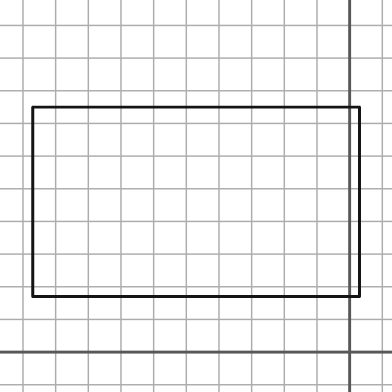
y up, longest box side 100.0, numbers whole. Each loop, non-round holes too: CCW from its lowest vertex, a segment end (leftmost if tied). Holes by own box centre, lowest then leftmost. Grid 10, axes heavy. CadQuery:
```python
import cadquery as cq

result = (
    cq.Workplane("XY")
    .moveTo(-97.0, 17.0)
    .lineTo(3.0, 17.0)
    .lineTo(3.0, 75.0)
    .lineTo(-97.0, 75.0)
    .close()
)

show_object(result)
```